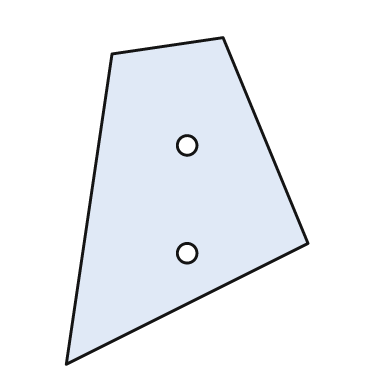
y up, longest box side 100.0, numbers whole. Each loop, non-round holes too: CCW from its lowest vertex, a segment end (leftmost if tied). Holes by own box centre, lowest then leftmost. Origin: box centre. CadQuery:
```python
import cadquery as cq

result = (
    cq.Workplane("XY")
    .moveTo(-37.0, -50.0)
    .lineTo(37.0, -13.0)
    .lineTo(11.0, 50.0)
    .lineTo(-23.0, 45.0)
    .close()
    .moveTo(0.0, -16.0)
    .circle(3.0)
    .moveTo(0.0, 17.0)
    .circle(3.0)
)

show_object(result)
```